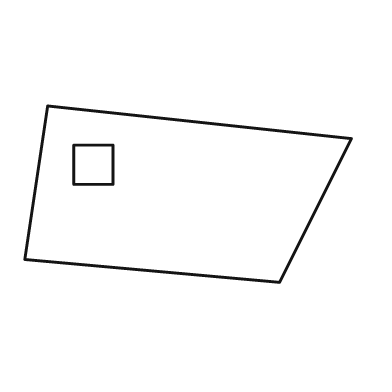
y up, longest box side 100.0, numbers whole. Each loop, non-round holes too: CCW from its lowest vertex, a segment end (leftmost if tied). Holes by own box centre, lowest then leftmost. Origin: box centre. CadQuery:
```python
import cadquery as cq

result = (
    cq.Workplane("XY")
    .moveTo(28.0, -27.0)
    .lineTo(50.0, 17.0)
    .lineTo(-43.0, 27.0)
    .lineTo(-50.0, -20.0)
    .close()
    .moveTo(-35.0, 3.0)
    .lineTo(-23.0, 3.0)
    .lineTo(-23.0, 15.0)
    .lineTo(-35.0, 15.0)
    .close()
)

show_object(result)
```